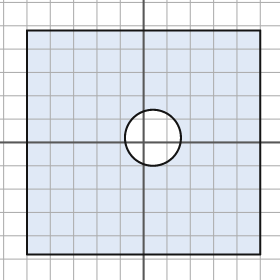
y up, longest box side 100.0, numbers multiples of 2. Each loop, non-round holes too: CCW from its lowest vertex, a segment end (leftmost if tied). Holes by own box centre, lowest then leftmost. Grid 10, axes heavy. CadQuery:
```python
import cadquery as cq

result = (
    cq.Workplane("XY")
    .moveTo(-50.0, -48.0)
    .lineTo(50.0, -48.0)
    .lineTo(50.0, 48.0)
    .lineTo(-50.0, 48.0)
    .close()
    .moveTo(4.0, 2.0)
    .circle(12.0)
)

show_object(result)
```